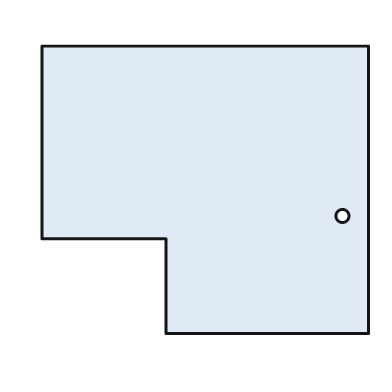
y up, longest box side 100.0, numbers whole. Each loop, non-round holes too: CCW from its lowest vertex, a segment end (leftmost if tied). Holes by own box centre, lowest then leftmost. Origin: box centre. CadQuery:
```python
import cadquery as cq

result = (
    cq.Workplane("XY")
    .moveTo(-12.0, -44.0)
    .lineTo(50.0, -44.0)
    .lineTo(50.0, 44.0)
    .lineTo(-50.0, 44.0)
    .lineTo(-50.0, -15.0)
    .lineTo(-12.0, -15.0)
    .close()
    .moveTo(42.0, -8.0)
    .circle(2.0)
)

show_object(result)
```